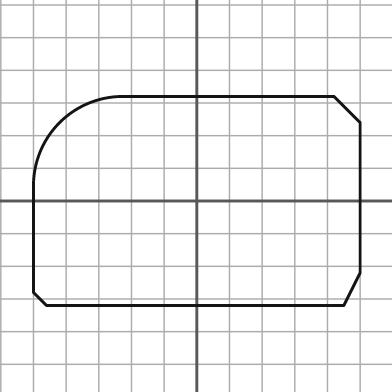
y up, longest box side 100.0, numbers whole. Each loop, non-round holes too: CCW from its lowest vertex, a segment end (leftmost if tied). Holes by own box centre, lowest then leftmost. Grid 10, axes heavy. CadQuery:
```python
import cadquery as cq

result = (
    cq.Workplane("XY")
    .moveTo(-46.0, -32.0)
    .lineTo(45.0, -32.0)
    .lineTo(50.0, -22.0)
    .lineTo(50.0, 24.0)
    .lineTo(42.0, 32.0)
    .lineTo(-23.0, 32.0)
    .threePointArc((-42.0, 24.0), (-50.0, 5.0))
    .lineTo(-50.0, -28.0)
    .close()
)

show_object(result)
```